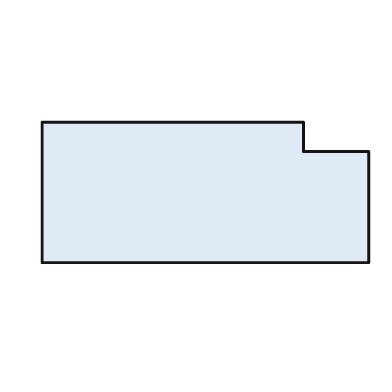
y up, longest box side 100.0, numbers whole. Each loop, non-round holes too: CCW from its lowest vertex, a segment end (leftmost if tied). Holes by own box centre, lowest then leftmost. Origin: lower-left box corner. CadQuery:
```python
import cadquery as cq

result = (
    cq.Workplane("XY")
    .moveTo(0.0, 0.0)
    .lineTo(100.0, 0.0)
    .lineTo(100.0, 34.0)
    .lineTo(80.0, 34.0)
    .lineTo(80.0, 43.0)
    .lineTo(0.0, 43.0)
    .close()
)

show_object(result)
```